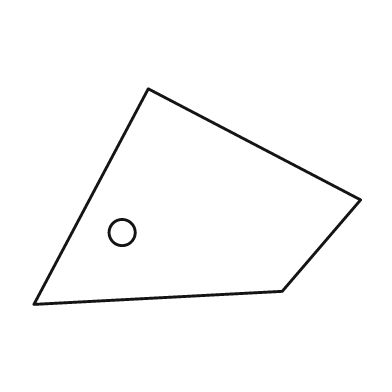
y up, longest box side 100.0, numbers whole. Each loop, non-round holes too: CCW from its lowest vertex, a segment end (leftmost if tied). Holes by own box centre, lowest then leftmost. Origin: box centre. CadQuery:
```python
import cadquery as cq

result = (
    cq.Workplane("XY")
    .moveTo(-50.0, -33.0)
    .lineTo(26.0, -29.0)
    .lineTo(50.0, -1.0)
    .lineTo(-15.0, 33.0)
    .close()
    .moveTo(-23.0, -11.0)
    .circle(4.0)
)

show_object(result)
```